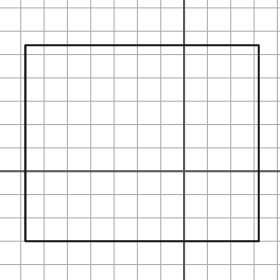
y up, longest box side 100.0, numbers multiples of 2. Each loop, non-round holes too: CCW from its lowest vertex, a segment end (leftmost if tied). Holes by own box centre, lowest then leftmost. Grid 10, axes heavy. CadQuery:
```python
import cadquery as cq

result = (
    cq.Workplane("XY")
    .moveTo(-68.0, -30.0)
    .lineTo(32.0, -30.0)
    .lineTo(32.0, 54.0)
    .lineTo(-68.0, 54.0)
    .close()
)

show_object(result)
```